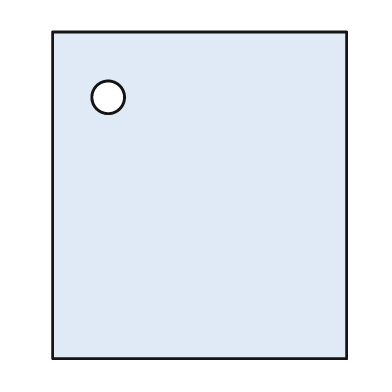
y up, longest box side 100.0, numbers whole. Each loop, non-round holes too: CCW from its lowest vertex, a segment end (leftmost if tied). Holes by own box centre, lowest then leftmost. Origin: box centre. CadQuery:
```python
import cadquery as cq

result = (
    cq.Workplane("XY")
    .moveTo(-45.0, -50.0)
    .lineTo(45.0, -50.0)
    .lineTo(45.0, 50.0)
    .lineTo(-45.0, 50.0)
    .close()
    .moveTo(-28.0, 30.0)
    .circle(5.0)
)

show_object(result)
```